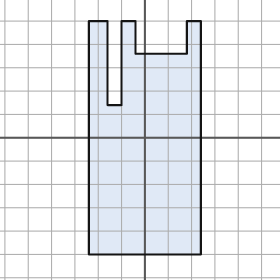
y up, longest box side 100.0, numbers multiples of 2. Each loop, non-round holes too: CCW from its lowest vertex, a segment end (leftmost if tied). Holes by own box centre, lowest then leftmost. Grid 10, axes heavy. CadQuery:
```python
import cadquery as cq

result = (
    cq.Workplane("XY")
    .moveTo(-24.0, -50.0)
    .lineTo(24.0, -50.0)
    .lineTo(24.0, 50.0)
    .lineTo(18.0, 50.0)
    .lineTo(18.0, 36.0)
    .lineTo(-4.0, 36.0)
    .lineTo(-4.0, 50.0)
    .lineTo(-10.0, 50.0)
    .lineTo(-10.0, 14.0)
    .lineTo(-16.0, 14.0)
    .lineTo(-16.0, 50.0)
    .lineTo(-24.0, 50.0)
    .close()
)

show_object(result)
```